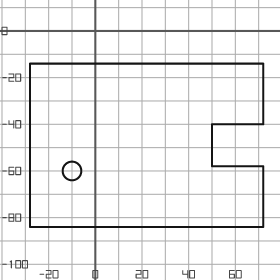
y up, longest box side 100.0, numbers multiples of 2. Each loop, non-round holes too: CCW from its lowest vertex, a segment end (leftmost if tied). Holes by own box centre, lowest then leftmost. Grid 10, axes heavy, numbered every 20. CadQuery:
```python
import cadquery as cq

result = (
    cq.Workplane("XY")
    .moveTo(-28.0, -84.0)
    .lineTo(72.0, -84.0)
    .lineTo(72.0, -58.0)
    .lineTo(50.0, -58.0)
    .lineTo(50.0, -40.0)
    .lineTo(72.0, -40.0)
    .lineTo(72.0, -14.0)
    .lineTo(-28.0, -14.0)
    .close()
    .moveTo(-10.0, -60.0)
    .circle(4.0)
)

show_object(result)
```